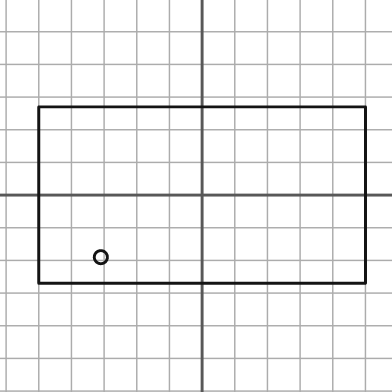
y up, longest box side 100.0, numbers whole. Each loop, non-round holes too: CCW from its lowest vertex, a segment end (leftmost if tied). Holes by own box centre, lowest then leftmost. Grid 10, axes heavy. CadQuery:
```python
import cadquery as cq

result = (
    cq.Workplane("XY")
    .moveTo(-50.0, -27.0)
    .lineTo(50.0, -27.0)
    .lineTo(50.0, 27.0)
    .lineTo(-50.0, 27.0)
    .close()
    .moveTo(-31.0, -19.0)
    .circle(2.0)
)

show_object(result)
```